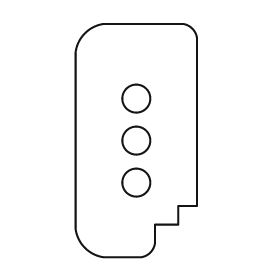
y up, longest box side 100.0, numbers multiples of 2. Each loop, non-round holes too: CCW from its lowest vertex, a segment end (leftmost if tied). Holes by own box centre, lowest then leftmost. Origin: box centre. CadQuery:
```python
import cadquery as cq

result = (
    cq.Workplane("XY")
    .moveTo(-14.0, -50.0)
    .lineTo(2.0, -50.0)
    .threePointArc((6.0, -48.0), (8.0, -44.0))
    .lineTo(8.0, -36.0)
    .lineTo(18.0, -36.0)
    .lineTo(18.0, -28.0)
    .lineTo(26.0, -28.0)
    .lineTo(26.0, 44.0)
    .threePointArc((24.0, 48.0), (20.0, 50.0))
    .lineTo(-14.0, 50.0)
    .threePointArc((-22.0, 46.0), (-26.0, 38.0))
    .lineTo(-26.0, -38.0)
    .threePointArc((-22.0, -46.0), (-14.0, -50.0))
    .close()
    .moveTo(0.0, -18.0)
    .circle(6.0)
    .moveTo(0.0, 0.0)
    .circle(6.0)
    .moveTo(0.0, 18.0)
    .circle(6.0)
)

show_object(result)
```